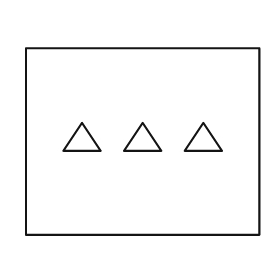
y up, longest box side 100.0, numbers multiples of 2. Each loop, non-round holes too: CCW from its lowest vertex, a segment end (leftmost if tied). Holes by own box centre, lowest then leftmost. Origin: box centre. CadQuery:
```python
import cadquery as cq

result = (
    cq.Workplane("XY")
    .moveTo(-50.0, -40.0)
    .lineTo(50.0, -40.0)
    .lineTo(50.0, 40.0)
    .lineTo(-50.0, 40.0)
    .close()
    .moveTo(-34.0, -4.0)
    .lineTo(-18.0, -4.0)
    .lineTo(-26.0, 8.0)
    .close()
    .moveTo(-8.0, -4.0)
    .lineTo(8.0, -4.0)
    .lineTo(0.0, 8.0)
    .close()
    .moveTo(18.0, -4.0)
    .lineTo(34.0, -4.0)
    .lineTo(26.0, 8.0)
    .close()
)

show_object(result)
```